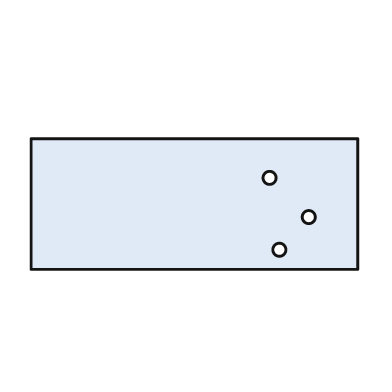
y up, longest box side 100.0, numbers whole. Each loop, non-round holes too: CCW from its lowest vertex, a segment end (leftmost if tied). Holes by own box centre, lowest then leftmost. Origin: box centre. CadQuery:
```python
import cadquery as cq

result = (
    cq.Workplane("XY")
    .moveTo(-50.0, -20.0)
    .lineTo(50.0, -20.0)
    .lineTo(50.0, 20.0)
    .lineTo(-50.0, 20.0)
    .close()
    .moveTo(26.0, -14.0)
    .circle(2.0)
    .moveTo(35.0, -4.0)
    .circle(2.0)
    .moveTo(23.0, 8.0)
    .circle(2.0)
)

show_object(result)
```